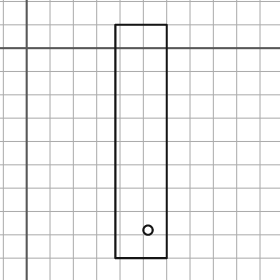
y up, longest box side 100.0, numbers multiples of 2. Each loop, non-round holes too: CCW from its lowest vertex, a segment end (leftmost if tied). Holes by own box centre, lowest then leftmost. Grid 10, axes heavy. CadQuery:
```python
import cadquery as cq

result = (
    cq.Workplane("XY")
    .moveTo(38.0, -90.0)
    .lineTo(60.0, -90.0)
    .lineTo(60.0, 10.0)
    .lineTo(38.0, 10.0)
    .close()
    .moveTo(52.0, -78.0)
    .circle(2.0)
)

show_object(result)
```